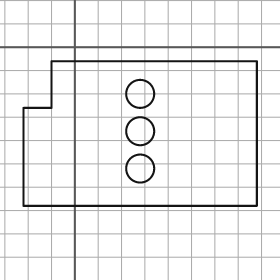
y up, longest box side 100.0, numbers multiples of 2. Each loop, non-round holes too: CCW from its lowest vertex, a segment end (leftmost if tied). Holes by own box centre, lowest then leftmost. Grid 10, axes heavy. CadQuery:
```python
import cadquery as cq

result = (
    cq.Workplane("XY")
    .moveTo(-22.0, -68.0)
    .lineTo(78.0, -68.0)
    .lineTo(78.0, -6.0)
    .lineTo(-10.0, -6.0)
    .lineTo(-10.0, -26.0)
    .lineTo(-22.0, -26.0)
    .close()
    .moveTo(28.0, -52.0)
    .circle(6.0)
    .moveTo(28.0, -36.0)
    .circle(6.0)
    .moveTo(28.0, -20.0)
    .circle(6.0)
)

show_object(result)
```